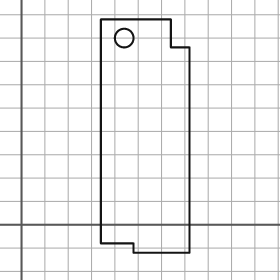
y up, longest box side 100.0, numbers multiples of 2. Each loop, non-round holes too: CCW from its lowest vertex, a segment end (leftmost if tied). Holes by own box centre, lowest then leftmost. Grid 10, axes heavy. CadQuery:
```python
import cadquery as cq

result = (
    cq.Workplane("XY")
    .moveTo(48.0, -12.0)
    .lineTo(72.0, -12.0)
    .lineTo(72.0, 76.0)
    .lineTo(64.0, 76.0)
    .lineTo(64.0, 88.0)
    .lineTo(34.0, 88.0)
    .lineTo(34.0, -8.0)
    .lineTo(48.0, -8.0)
    .close()
    .moveTo(44.0, 80.0)
    .circle(4.0)
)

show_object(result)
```